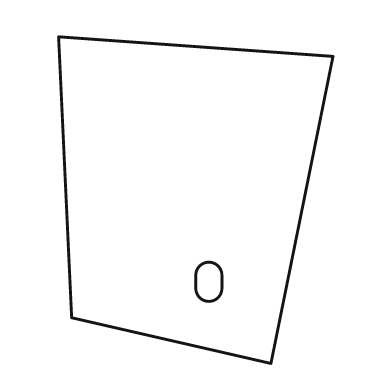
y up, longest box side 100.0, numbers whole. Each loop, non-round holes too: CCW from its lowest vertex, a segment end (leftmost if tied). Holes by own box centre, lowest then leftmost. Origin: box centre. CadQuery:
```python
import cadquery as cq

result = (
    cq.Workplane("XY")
    .moveTo(23.0, -50.0)
    .lineTo(42.0, 44.0)
    .lineTo(-42.0, 50.0)
    .lineTo(-38.0, -36.0)
    .close()
    .moveTo(0.0, -27.0)
    .threePointArc((4.0, -31.0), (8.0, -27.0))
    .lineTo(8.0, -23.0)
    .threePointArc((4.0, -19.0), (0.0, -23.0))
    .close()
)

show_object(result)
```